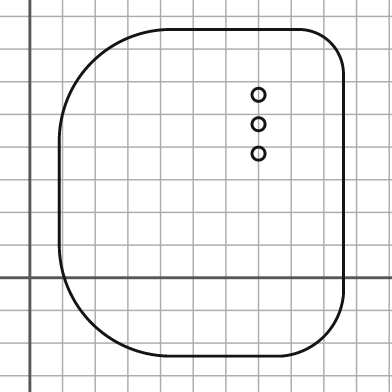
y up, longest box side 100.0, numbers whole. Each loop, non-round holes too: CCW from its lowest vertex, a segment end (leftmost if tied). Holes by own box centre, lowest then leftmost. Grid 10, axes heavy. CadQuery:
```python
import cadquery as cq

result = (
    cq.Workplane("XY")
    .moveTo(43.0, -24.0)
    .lineTo(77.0, -24.0)
    .threePointArc((90.0, -18.0), (96.0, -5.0))
    .lineTo(96.0, 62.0)
    .threePointArc((92.0, 72.0), (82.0, 76.0))
    .lineTo(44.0, 76.0)
    .threePointArc((19.0, 66.0), (9.0, 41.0))
    .lineTo(9.0, 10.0)
    .threePointArc((19.0, -14.0), (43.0, -24.0))
    .close()
    .moveTo(70.0, 38.0)
    .circle(2.0)
    .moveTo(70.0, 47.0)
    .circle(2.0)
    .moveTo(70.0, 56.0)
    .circle(2.0)
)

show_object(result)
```